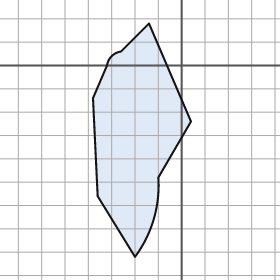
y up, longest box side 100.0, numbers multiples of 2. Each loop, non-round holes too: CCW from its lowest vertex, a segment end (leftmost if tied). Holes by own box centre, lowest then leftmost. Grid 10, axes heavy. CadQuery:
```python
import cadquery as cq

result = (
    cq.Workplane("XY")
    .moveTo(-20.0, -82.0)
    .threePointArc((-12.0, -66.0), (-10.0, -48.0))
    .lineTo(4.0, -24.0)
    .lineTo(-14.0, 18.0)
    .lineTo(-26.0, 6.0)
    .threePointArc((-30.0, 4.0), (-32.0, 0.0))
    .lineTo(-38.0, -14.0)
    .lineTo(-36.0, -56.0)
    .close()
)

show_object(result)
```